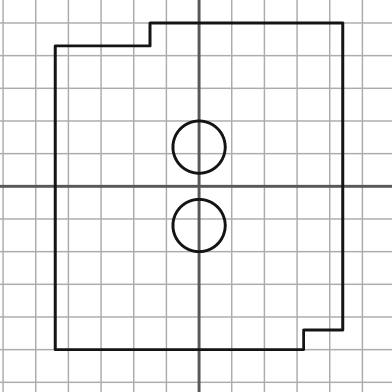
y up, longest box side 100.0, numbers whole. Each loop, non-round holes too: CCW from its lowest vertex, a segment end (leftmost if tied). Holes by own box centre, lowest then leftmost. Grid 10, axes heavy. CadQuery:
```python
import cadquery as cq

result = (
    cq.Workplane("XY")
    .moveTo(-44.0, -50.0)
    .lineTo(32.0, -50.0)
    .lineTo(32.0, -44.0)
    .lineTo(44.0, -44.0)
    .lineTo(44.0, 50.0)
    .lineTo(-15.0, 50.0)
    .lineTo(-15.0, 43.0)
    .lineTo(-44.0, 43.0)
    .close()
    .moveTo(0.0, -12.0)
    .circle(8.0)
    .moveTo(0.0, 12.0)
    .circle(8.0)
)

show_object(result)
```